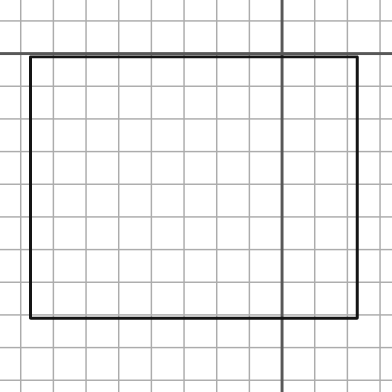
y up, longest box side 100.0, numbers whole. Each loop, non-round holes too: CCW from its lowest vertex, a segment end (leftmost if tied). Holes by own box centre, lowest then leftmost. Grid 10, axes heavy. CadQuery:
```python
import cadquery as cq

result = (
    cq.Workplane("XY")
    .moveTo(-77.0, -81.0)
    .lineTo(23.0, -81.0)
    .lineTo(23.0, -1.0)
    .lineTo(-77.0, -1.0)
    .close()
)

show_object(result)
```